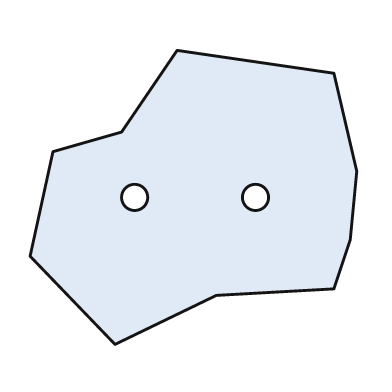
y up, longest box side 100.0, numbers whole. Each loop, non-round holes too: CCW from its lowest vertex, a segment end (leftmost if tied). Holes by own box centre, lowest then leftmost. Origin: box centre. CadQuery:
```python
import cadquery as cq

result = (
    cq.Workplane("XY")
    .moveTo(-24.0, -45.0)
    .lineTo(7.0, -30.0)
    .lineTo(43.0, -28.0)
    .lineTo(48.0, -13.0)
    .lineTo(50.0, 8.0)
    .lineTo(43.0, 38.0)
    .lineTo(-5.0, 45.0)
    .lineTo(-22.0, 20.0)
    .lineTo(-43.0, 14.0)
    .lineTo(-50.0, -18.0)
    .close()
    .moveTo(-18.0, 0.0)
    .circle(4.0)
    .moveTo(19.0, 0.0)
    .circle(4.0)
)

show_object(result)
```